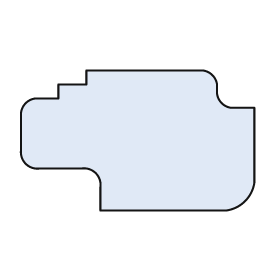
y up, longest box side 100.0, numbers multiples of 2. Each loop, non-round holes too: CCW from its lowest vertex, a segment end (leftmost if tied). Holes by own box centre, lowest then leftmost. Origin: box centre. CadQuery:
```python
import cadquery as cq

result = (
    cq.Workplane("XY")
    .moveTo(-16.0, -30.0)
    .lineTo(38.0, -30.0)
    .threePointArc((46.0, -26.0), (50.0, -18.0))
    .lineTo(50.0, 14.0)
    .lineTo(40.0, 14.0)
    .threePointArc((36.0, 16.0), (34.0, 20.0))
    .lineTo(34.0, 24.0)
    .threePointArc((32.0, 28.0), (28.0, 30.0))
    .lineTo(-22.0, 30.0)
    .lineTo(-22.0, 24.0)
    .lineTo(-34.0, 24.0)
    .lineTo(-34.0, 18.0)
    .lineTo(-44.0, 18.0)
    .threePointArc((-48.0, 16.0), (-50.0, 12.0))
    .lineTo(-50.0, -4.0)
    .threePointArc((-48.0, -10.0), (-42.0, -12.0))
    .lineTo(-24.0, -12.0)
    .threePointArc((-18.0, -14.0), (-16.0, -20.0))
    .close()
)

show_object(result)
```